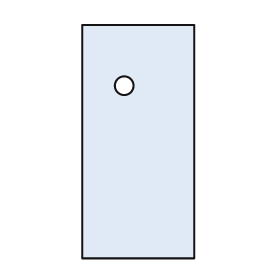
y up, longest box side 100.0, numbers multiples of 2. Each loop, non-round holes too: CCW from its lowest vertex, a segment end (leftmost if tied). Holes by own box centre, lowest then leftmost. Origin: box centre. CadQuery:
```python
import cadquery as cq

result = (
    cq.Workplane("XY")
    .moveTo(-24.0, -50.0)
    .lineTo(24.0, -50.0)
    .lineTo(24.0, 50.0)
    .lineTo(-24.0, 50.0)
    .close()
    .moveTo(-6.0, 24.0)
    .circle(4.0)
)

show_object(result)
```